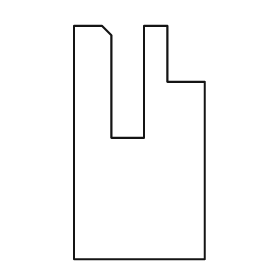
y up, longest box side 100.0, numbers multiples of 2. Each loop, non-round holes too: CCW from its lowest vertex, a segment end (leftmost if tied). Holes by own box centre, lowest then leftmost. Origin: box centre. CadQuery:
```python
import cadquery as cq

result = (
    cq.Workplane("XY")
    .moveTo(-28.0, -50.0)
    .lineTo(28.0, -50.0)
    .lineTo(28.0, 26.0)
    .lineTo(12.0, 26.0)
    .lineTo(12.0, 50.0)
    .lineTo(2.0, 50.0)
    .lineTo(2.0, 2.0)
    .lineTo(-12.0, 2.0)
    .lineTo(-12.0, 46.0)
    .lineTo(-16.0, 50.0)
    .lineTo(-28.0, 50.0)
    .close()
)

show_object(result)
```